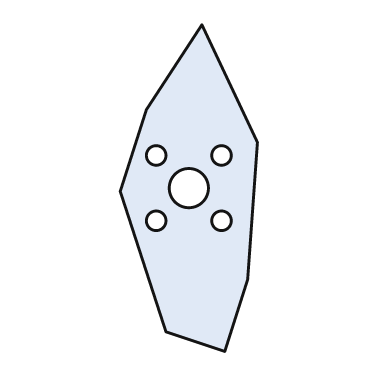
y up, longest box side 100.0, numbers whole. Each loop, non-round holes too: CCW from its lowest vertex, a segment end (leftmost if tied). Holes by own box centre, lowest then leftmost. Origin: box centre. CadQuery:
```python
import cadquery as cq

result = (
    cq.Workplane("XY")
    .moveTo(11.0, -50.0)
    .lineTo(18.0, -28.0)
    .lineTo(21.0, 14.0)
    .lineTo(4.0, 50.0)
    .lineTo(-13.0, 24.0)
    .lineTo(-21.0, -1.0)
    .lineTo(-7.0, -44.0)
    .close()
    .moveTo(-10.0, -10.0)
    .circle(3.0)
    .moveTo(10.0, -10.0)
    .circle(3.0)
    .moveTo(0.0, 0.0)
    .circle(6.0)
    .moveTo(-10.0, 10.0)
    .circle(3.0)
    .moveTo(10.0, 10.0)
    .circle(3.0)
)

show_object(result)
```